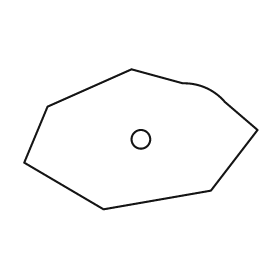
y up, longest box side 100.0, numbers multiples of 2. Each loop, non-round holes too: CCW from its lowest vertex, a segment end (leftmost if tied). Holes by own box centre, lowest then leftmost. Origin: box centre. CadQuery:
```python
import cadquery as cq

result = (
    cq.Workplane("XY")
    .moveTo(-16.0, -30.0)
    .lineTo(30.0, -22.0)
    .lineTo(50.0, 4.0)
    .lineTo(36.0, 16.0)
    .threePointArc((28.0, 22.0), (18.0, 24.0))
    .lineTo(-4.0, 30.0)
    .lineTo(-40.0, 14.0)
    .lineTo(-50.0, -10.0)
    .close()
    .moveTo(0.0, 0.0)
    .circle(4.0)
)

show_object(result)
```